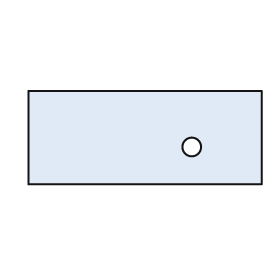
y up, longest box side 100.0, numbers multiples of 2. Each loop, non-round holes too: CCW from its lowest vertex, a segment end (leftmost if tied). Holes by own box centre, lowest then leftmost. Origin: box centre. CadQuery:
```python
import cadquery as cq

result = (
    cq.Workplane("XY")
    .moveTo(-50.0, -20.0)
    .lineTo(50.0, -20.0)
    .lineTo(50.0, 20.0)
    .lineTo(-50.0, 20.0)
    .close()
    .moveTo(20.0, -4.0)
    .circle(4.0)
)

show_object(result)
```